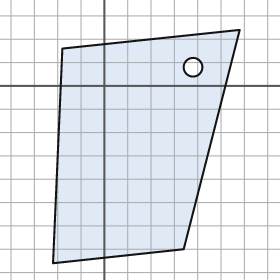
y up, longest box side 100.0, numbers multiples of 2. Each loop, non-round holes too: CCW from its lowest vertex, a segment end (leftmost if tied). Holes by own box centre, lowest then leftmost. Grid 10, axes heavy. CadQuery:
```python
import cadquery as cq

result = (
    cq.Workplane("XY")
    .moveTo(-22.0, -76.0)
    .lineTo(34.0, -70.0)
    .lineTo(58.0, 24.0)
    .lineTo(-18.0, 16.0)
    .close()
    .moveTo(38.0, 8.0)
    .circle(4.0)
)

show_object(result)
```